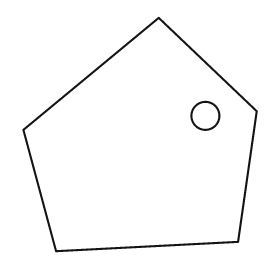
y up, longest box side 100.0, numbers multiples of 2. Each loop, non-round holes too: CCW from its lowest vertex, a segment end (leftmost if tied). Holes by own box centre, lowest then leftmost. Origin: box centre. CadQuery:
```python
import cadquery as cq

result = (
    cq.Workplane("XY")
    .moveTo(-36.0, -50.0)
    .lineTo(42.0, -46.0)
    .lineTo(50.0, 10.0)
    .lineTo(8.0, 50.0)
    .lineTo(-50.0, 2.0)
    .close()
    .moveTo(28.0, 8.0)
    .circle(6.0)
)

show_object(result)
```